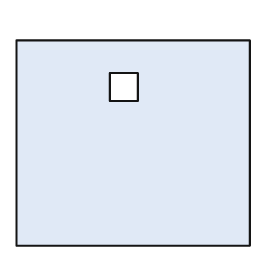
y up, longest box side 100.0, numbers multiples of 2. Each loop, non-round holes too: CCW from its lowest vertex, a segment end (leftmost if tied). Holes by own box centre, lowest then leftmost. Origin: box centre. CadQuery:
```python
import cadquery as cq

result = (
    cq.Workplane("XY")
    .moveTo(-50.0, -44.0)
    .lineTo(50.0, -44.0)
    .lineTo(50.0, 44.0)
    .lineTo(-50.0, 44.0)
    .close()
    .moveTo(-10.0, 18.0)
    .lineTo(2.0, 18.0)
    .lineTo(2.0, 30.0)
    .lineTo(-10.0, 30.0)
    .close()
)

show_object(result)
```